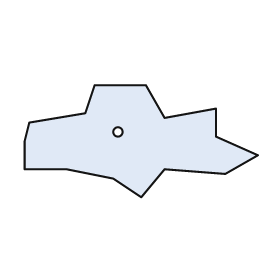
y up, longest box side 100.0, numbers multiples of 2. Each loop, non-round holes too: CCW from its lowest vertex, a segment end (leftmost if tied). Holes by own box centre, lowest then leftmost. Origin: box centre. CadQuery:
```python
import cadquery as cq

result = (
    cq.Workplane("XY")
    .moveTo(0.0, -24.0)
    .lineTo(10.0, -12.0)
    .lineTo(36.0, -14.0)
    .lineTo(50.0, -6.0)
    .lineTo(32.0, 2.0)
    .lineTo(32.0, 14.0)
    .lineTo(10.0, 10.0)
    .lineTo(2.0, 24.0)
    .lineTo(-20.0, 24.0)
    .lineTo(-24.0, 12.0)
    .lineTo(-48.0, 8.0)
    .lineTo(-50.0, 0.0)
    .lineTo(-50.0, -12.0)
    .lineTo(-32.0, -12.0)
    .lineTo(-12.0, -16.0)
    .close()
    .moveTo(-10.0, 4.0)
    .circle(2.0)
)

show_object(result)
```